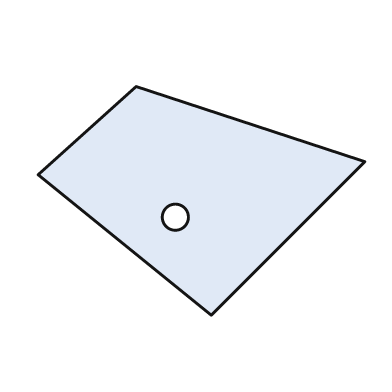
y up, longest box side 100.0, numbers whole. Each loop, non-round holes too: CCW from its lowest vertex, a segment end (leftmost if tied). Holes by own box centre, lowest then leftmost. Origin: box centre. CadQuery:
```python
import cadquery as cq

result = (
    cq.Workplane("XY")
    .moveTo(3.0, -35.0)
    .lineTo(50.0, 12.0)
    .lineTo(-20.0, 35.0)
    .lineTo(-50.0, 8.0)
    .close()
    .moveTo(-8.0, -5.0)
    .circle(4.0)
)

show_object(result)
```